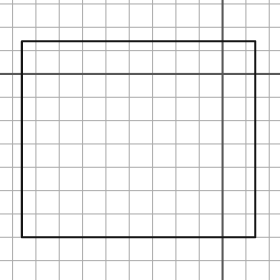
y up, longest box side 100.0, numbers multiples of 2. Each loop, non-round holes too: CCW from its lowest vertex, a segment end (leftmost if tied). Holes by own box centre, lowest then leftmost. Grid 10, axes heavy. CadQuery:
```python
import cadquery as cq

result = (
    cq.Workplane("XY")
    .moveTo(-86.0, -70.0)
    .lineTo(14.0, -70.0)
    .lineTo(14.0, 14.0)
    .lineTo(-86.0, 14.0)
    .close()
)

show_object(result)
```